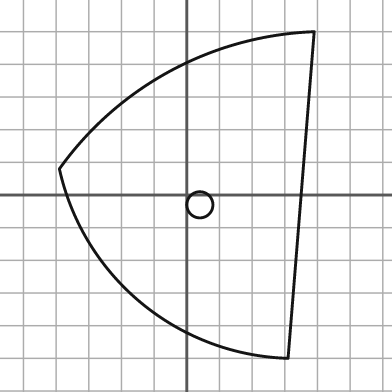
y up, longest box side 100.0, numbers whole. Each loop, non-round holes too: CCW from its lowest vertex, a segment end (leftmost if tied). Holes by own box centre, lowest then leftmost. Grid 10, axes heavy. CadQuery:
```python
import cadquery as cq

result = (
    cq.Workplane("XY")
    .moveTo(31.0, -50.0)
    .lineTo(39.0, 50.0)
    .threePointArc((-5.0, 38.0), (-39.0, 8.0))
    .threePointArc((-14.0, -33.0), (31.0, -50.0))
    .close()
    .moveTo(4.0, -3.0)
    .circle(4.0)
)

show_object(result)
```